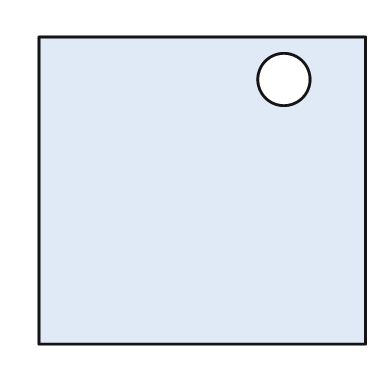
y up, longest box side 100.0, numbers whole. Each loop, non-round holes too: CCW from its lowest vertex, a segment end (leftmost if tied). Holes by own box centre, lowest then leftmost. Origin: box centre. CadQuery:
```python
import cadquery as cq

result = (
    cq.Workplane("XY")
    .moveTo(-50.0, -47.0)
    .lineTo(50.0, -47.0)
    .lineTo(50.0, 47.0)
    .lineTo(-50.0, 47.0)
    .close()
    .moveTo(25.0, 34.0)
    .circle(8.0)
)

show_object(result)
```